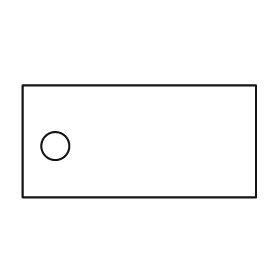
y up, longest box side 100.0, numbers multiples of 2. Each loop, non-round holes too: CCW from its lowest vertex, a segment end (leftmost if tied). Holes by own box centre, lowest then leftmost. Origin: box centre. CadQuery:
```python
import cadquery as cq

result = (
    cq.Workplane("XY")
    .moveTo(-50.0, -24.0)
    .lineTo(50.0, -24.0)
    .lineTo(50.0, 24.0)
    .lineTo(-50.0, 24.0)
    .close()
    .moveTo(-36.0, -2.0)
    .circle(6.0)
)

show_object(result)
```